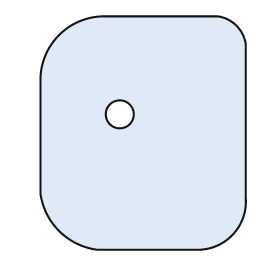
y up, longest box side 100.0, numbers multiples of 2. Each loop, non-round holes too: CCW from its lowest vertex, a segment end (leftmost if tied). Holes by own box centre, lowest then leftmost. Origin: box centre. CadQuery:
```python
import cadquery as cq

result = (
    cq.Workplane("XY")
    .moveTo(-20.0, -50.0)
    .lineTo(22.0, -50.0)
    .threePointArc((38.0, -44.0), (44.0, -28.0))
    .lineTo(44.0, 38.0)
    .threePointArc((40.0, 46.0), (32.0, 50.0))
    .lineTo(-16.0, 50.0)
    .threePointArc((-36.0, 42.0), (-44.0, 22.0))
    .lineTo(-44.0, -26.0)
    .threePointArc((-36.0, -42.0), (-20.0, -50.0))
    .close()
    .moveTo(-10.0, 8.0)
    .circle(6.0)
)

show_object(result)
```